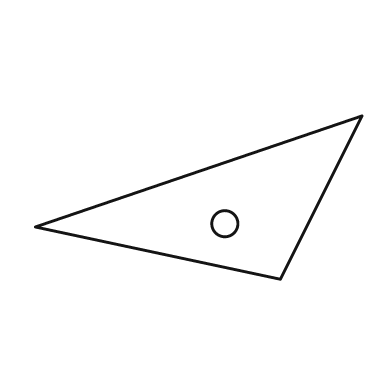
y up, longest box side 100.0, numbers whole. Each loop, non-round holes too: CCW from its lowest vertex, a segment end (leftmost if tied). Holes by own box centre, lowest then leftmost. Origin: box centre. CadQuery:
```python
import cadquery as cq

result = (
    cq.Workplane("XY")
    .moveTo(25.0, -25.0)
    .lineTo(50.0, 25.0)
    .lineTo(-50.0, -9.0)
    .close()
    .moveTo(8.0, -8.0)
    .circle(4.0)
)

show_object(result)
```